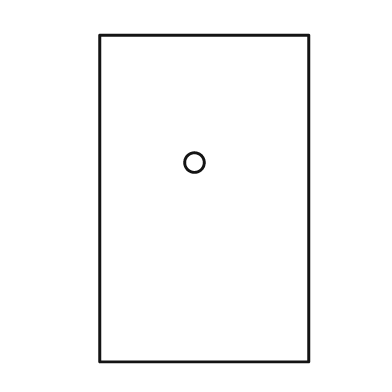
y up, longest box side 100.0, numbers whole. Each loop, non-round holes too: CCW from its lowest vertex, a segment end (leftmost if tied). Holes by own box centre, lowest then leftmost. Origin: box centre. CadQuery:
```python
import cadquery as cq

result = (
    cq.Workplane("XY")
    .moveTo(-32.0, -50.0)
    .lineTo(32.0, -50.0)
    .lineTo(32.0, 50.0)
    .lineTo(-32.0, 50.0)
    .close()
    .moveTo(-3.0, 11.0)
    .circle(3.0)
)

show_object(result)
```